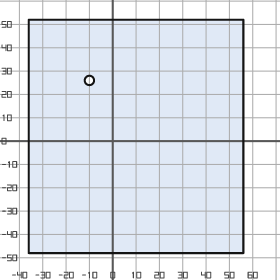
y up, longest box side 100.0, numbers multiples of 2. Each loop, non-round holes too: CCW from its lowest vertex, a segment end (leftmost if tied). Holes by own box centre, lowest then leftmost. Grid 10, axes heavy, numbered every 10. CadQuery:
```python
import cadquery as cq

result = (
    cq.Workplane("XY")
    .moveTo(-36.0, -48.0)
    .lineTo(56.0, -48.0)
    .lineTo(56.0, 52.0)
    .lineTo(-36.0, 52.0)
    .close()
    .moveTo(-10.0, 26.0)
    .circle(2.0)
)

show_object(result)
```